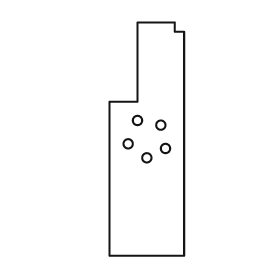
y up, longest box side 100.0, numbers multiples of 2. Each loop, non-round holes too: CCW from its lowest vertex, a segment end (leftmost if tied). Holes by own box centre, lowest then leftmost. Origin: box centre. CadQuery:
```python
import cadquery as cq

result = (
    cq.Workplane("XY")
    .moveTo(-16.0, -50.0)
    .lineTo(16.0, -50.0)
    .lineTo(16.0, 46.0)
    .lineTo(12.0, 46.0)
    .lineTo(12.0, 50.0)
    .lineTo(-4.0, 50.0)
    .lineTo(-4.0, 16.0)
    .lineTo(-16.0, 16.0)
    .close()
    .moveTo(0.0, -8.0)
    .circle(2.0)
    .moveTo(8.0, -4.0)
    .circle(2.0)
    .moveTo(-8.0, -2.0)
    .circle(2.0)
    .moveTo(6.0, 6.0)
    .circle(2.0)
    .moveTo(-4.0, 8.0)
    .circle(2.0)
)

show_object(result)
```